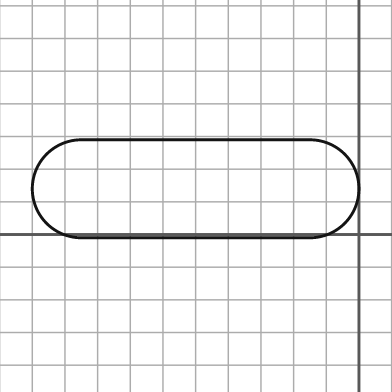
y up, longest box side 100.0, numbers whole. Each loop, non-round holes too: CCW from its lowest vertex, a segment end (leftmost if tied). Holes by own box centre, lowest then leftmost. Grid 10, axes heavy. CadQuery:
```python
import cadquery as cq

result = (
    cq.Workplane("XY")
    .moveTo(-85.0, -1.0)
    .lineTo(-15.0, -1.0)
    .threePointArc((0.0, 14.0), (-15.0, 29.0))
    .lineTo(-85.0, 29.0)
    .threePointArc((-100.0, 14.0), (-85.0, -1.0))
    .close()
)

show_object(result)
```